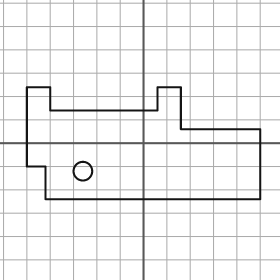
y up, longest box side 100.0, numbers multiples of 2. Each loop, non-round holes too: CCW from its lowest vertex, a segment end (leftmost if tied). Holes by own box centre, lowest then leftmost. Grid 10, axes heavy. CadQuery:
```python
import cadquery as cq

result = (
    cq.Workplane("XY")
    .moveTo(-42.0, -24.0)
    .lineTo(50.0, -24.0)
    .lineTo(50.0, 6.0)
    .lineTo(16.0, 6.0)
    .lineTo(16.0, 24.0)
    .lineTo(6.0, 24.0)
    .lineTo(6.0, 14.0)
    .lineTo(-40.0, 14.0)
    .lineTo(-40.0, 24.0)
    .lineTo(-50.0, 24.0)
    .lineTo(-50.0, -10.0)
    .lineTo(-42.0, -10.0)
    .close()
    .moveTo(-26.0, -12.0)
    .circle(4.0)
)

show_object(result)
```